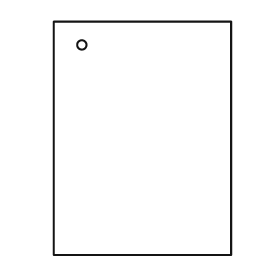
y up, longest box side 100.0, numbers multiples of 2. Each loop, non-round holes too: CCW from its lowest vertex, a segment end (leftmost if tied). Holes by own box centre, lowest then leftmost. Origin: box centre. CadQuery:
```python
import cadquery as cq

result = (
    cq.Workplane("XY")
    .moveTo(-38.0, -50.0)
    .lineTo(38.0, -50.0)
    .lineTo(38.0, 50.0)
    .lineTo(-38.0, 50.0)
    .close()
    .moveTo(-26.0, 40.0)
    .circle(2.0)
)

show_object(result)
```